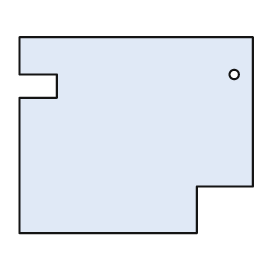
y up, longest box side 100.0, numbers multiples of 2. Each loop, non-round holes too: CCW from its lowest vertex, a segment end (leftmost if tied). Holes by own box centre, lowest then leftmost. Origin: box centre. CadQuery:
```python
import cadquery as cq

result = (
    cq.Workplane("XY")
    .moveTo(-50.0, -42.0)
    .lineTo(26.0, -42.0)
    .lineTo(26.0, -22.0)
    .lineTo(50.0, -22.0)
    .lineTo(50.0, 42.0)
    .lineTo(-50.0, 42.0)
    .lineTo(-50.0, 26.0)
    .lineTo(-34.0, 26.0)
    .lineTo(-34.0, 16.0)
    .lineTo(-50.0, 16.0)
    .close()
    .moveTo(42.0, 26.0)
    .circle(2.0)
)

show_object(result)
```